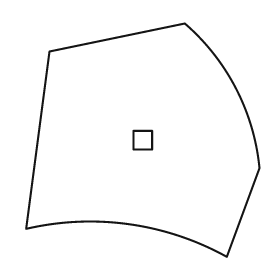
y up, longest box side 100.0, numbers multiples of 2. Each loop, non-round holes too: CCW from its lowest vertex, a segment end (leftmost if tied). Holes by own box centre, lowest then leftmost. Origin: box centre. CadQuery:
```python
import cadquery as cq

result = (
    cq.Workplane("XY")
    .moveTo(36.0, -50.0)
    .lineTo(50.0, -12.0)
    .threePointArc((40.0, 22.0), (18.0, 50.0))
    .lineTo(-40.0, 38.0)
    .lineTo(-50.0, -38.0)
    .threePointArc((-6.0, -36.0), (36.0, -50.0))
    .close()
    .moveTo(-4.0, -4.0)
    .lineTo(4.0, -4.0)
    .lineTo(4.0, 4.0)
    .lineTo(-4.0, 4.0)
    .close()
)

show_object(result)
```